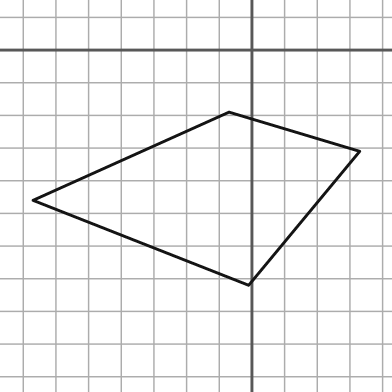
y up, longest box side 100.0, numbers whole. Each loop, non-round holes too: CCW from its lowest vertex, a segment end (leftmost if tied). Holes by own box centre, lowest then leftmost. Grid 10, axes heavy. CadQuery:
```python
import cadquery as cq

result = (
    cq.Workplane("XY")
    .moveTo(-1.0, -72.0)
    .lineTo(33.0, -31.0)
    .lineTo(-7.0, -19.0)
    .lineTo(-67.0, -46.0)
    .close()
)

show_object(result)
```